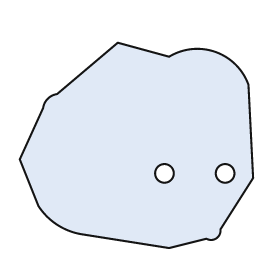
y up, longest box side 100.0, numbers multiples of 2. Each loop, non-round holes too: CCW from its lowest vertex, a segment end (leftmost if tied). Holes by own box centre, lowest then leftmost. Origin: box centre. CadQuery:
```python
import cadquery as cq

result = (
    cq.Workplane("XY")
    .moveTo(14.0, -44.0)
    .lineTo(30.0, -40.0)
    .threePointArc((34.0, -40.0), (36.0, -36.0))
    .lineTo(50.0, -14.0)
    .lineTo(48.0, 26.0)
    .threePointArc((34.0, 40.0), (14.0, 38.0))
    .lineTo(-8.0, 44.0)
    .lineTo(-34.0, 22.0)
    .threePointArc((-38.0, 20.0), (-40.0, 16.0))
    .lineTo(-50.0, -6.0)
    .lineTo(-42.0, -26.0)
    .threePointArc((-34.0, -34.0), (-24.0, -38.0))
    .close()
    .moveTo(12.0, -12.0)
    .circle(4.0)
    .moveTo(38.0, -12.0)
    .circle(4.0)
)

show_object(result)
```